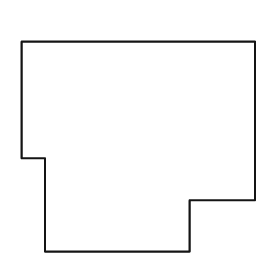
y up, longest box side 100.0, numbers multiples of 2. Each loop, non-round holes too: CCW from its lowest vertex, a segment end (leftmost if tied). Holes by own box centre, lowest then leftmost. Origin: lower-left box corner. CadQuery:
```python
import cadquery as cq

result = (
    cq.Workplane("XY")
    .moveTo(10.0, 0.0)
    .lineTo(72.0, 0.0)
    .lineTo(72.0, 22.0)
    .lineTo(100.0, 22.0)
    .lineTo(100.0, 90.0)
    .lineTo(0.0, 90.0)
    .lineTo(0.0, 40.0)
    .lineTo(10.0, 40.0)
    .close()
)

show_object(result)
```